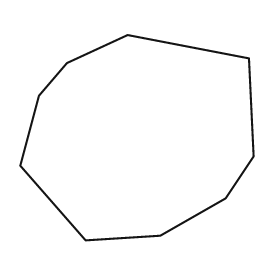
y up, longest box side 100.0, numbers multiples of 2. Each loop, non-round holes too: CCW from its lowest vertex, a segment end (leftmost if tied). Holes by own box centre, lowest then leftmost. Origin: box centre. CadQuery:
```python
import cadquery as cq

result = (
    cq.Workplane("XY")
    .moveTo(-22.0, -44.0)
    .lineTo(10.0, -42.0)
    .lineTo(38.0, -26.0)
    .lineTo(50.0, -8.0)
    .lineTo(48.0, 34.0)
    .lineTo(-4.0, 44.0)
    .lineTo(-30.0, 32.0)
    .lineTo(-42.0, 18.0)
    .lineTo(-50.0, -12.0)
    .close()
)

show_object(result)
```